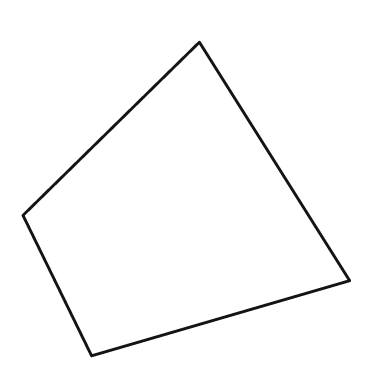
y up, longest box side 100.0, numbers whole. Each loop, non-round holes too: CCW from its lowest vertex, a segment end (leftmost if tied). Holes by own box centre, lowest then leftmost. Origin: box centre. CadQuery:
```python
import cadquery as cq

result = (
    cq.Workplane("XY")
    .moveTo(-29.0, -48.0)
    .lineTo(50.0, -25.0)
    .lineTo(4.0, 48.0)
    .lineTo(-50.0, -5.0)
    .close()
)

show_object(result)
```